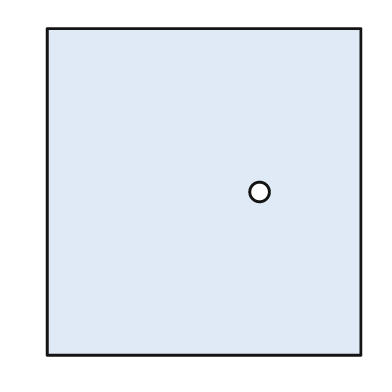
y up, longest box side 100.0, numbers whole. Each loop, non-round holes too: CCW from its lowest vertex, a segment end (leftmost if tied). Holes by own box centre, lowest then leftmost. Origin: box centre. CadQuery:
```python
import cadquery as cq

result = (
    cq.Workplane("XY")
    .moveTo(-48.0, -50.0)
    .lineTo(48.0, -50.0)
    .lineTo(48.0, 50.0)
    .lineTo(-48.0, 50.0)
    .close()
    .moveTo(17.0, 0.0)
    .circle(3.0)
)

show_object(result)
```